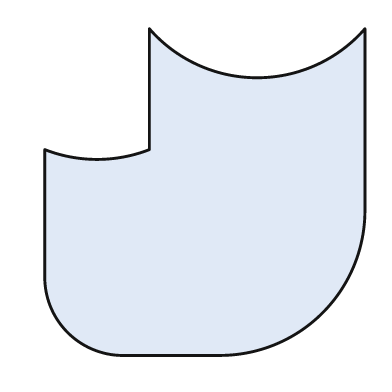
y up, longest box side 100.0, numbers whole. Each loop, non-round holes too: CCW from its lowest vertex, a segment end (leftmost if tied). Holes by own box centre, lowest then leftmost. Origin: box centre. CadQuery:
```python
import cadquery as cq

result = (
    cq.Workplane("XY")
    .moveTo(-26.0, -50.0)
    .lineTo(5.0, -50.0)
    .threePointArc((36.0, -37.0), (49.0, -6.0))
    .lineTo(49.0, 50.0)
    .threePointArc((16.0, 35.0), (-17.0, 50.0))
    .lineTo(-17.0, 13.0)
    .threePointArc((-33.0, 10.0), (-49.0, 13.0))
    .lineTo(-49.0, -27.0)
    .threePointArc((-42.0, -43.0), (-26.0, -50.0))
    .close()
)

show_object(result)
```